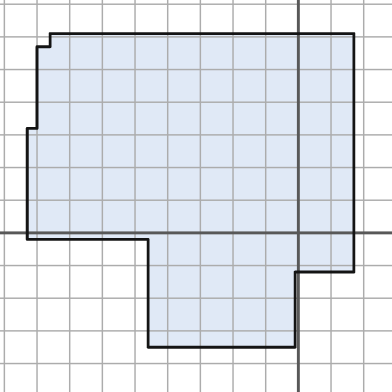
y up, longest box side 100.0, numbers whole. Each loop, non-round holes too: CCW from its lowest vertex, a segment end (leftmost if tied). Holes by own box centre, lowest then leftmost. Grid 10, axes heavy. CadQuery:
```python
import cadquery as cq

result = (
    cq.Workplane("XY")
    .moveTo(-46.0, -35.0)
    .lineTo(-1.0, -35.0)
    .lineTo(-1.0, -12.0)
    .lineTo(17.0, -12.0)
    .lineTo(17.0, 61.0)
    .lineTo(-76.0, 61.0)
    .lineTo(-76.0, 57.0)
    .lineTo(-80.0, 57.0)
    .lineTo(-80.0, 32.0)
    .lineTo(-83.0, 32.0)
    .lineTo(-83.0, -2.0)
    .lineTo(-46.0, -2.0)
    .close()
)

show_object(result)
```